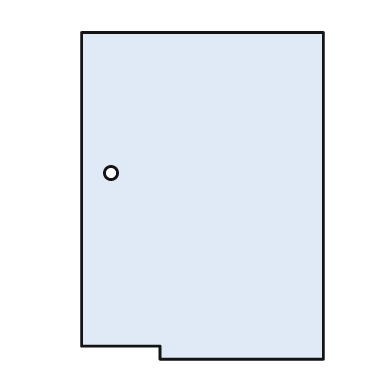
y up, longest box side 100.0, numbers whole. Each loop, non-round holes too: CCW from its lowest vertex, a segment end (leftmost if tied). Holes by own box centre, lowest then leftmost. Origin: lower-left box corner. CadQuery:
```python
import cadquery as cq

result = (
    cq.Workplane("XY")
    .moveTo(24.0, 0.0)
    .lineTo(74.0, 0.0)
    .lineTo(74.0, 100.0)
    .lineTo(0.0, 100.0)
    .lineTo(0.0, 4.0)
    .lineTo(24.0, 4.0)
    .close()
    .moveTo(9.0, 57.0)
    .circle(2.0)
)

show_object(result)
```